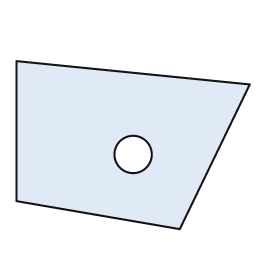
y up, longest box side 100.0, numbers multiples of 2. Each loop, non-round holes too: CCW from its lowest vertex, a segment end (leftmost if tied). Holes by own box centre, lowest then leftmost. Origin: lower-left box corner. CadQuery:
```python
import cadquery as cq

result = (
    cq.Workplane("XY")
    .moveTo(70.0, 0.0)
    .lineTo(100.0, 62.0)
    .lineTo(0.0, 72.0)
    .lineTo(0.0, 12.0)
    .close()
    .moveTo(50.0, 32.0)
    .circle(8.0)
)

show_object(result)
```